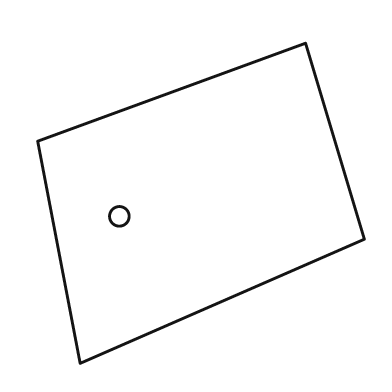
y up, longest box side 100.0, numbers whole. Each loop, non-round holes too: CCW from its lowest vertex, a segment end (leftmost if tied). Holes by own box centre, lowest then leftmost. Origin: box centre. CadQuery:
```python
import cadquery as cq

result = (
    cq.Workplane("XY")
    .moveTo(-37.0, -49.0)
    .lineTo(50.0, -11.0)
    .lineTo(32.0, 49.0)
    .lineTo(-50.0, 19.0)
    .close()
    .moveTo(-25.0, -4.0)
    .circle(3.0)
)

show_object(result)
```